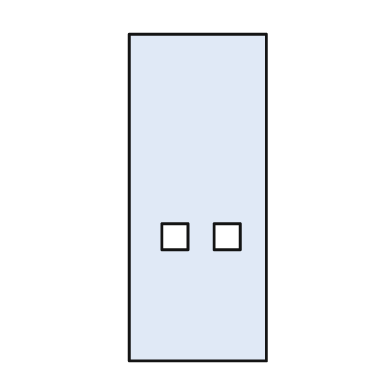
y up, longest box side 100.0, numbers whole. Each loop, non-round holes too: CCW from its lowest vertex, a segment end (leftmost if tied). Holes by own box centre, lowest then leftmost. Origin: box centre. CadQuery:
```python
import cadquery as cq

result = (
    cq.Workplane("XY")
    .moveTo(-21.0, -50.0)
    .lineTo(21.0, -50.0)
    .lineTo(21.0, 50.0)
    .lineTo(-21.0, 50.0)
    .close()
    .moveTo(-11.0, -16.0)
    .lineTo(-3.0, -16.0)
    .lineTo(-3.0, -8.0)
    .lineTo(-11.0, -8.0)
    .close()
    .moveTo(5.0, -16.0)
    .lineTo(13.0, -16.0)
    .lineTo(13.0, -8.0)
    .lineTo(5.0, -8.0)
    .close()
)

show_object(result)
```